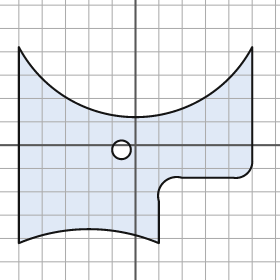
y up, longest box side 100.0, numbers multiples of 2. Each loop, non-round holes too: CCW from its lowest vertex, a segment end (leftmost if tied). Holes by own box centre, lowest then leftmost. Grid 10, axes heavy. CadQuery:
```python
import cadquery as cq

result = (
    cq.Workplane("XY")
    .moveTo(-50.0, -42.0)
    .threePointArc((-20.0, -36.0), (10.0, -42.0))
    .lineTo(10.0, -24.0)
    .threePointArc((12.0, -16.0), (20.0, -14.0))
    .lineTo(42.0, -14.0)
    .threePointArc((48.0, -12.0), (50.0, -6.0))
    .lineTo(50.0, 42.0)
    .threePointArc((0.0, 12.0), (-50.0, 42.0))
    .close()
    .moveTo(-6.0, -2.0)
    .circle(4.0)
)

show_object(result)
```